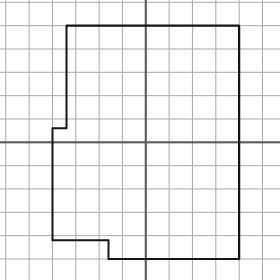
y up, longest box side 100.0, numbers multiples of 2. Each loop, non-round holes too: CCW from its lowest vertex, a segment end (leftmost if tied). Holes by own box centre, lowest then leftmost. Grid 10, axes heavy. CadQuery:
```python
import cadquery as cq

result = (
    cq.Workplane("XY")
    .moveTo(-16.0, -50.0)
    .lineTo(40.0, -50.0)
    .lineTo(40.0, 50.0)
    .lineTo(-34.0, 50.0)
    .lineTo(-34.0, 6.0)
    .lineTo(-40.0, 6.0)
    .lineTo(-40.0, -42.0)
    .lineTo(-16.0, -42.0)
    .close()
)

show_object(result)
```